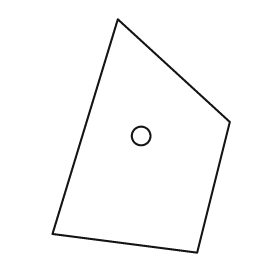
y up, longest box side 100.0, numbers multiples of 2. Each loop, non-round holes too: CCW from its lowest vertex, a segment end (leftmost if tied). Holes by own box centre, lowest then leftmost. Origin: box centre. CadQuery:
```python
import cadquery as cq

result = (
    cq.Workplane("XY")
    .moveTo(24.0, -50.0)
    .lineTo(38.0, 6.0)
    .lineTo(-10.0, 50.0)
    .lineTo(-38.0, -42.0)
    .close()
    .moveTo(0.0, 0.0)
    .circle(4.0)
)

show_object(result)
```